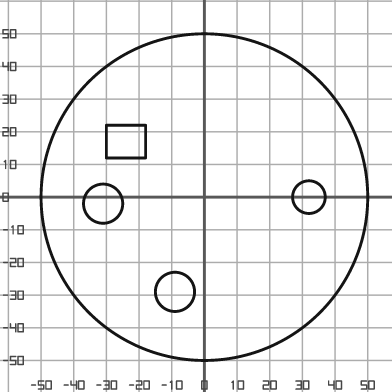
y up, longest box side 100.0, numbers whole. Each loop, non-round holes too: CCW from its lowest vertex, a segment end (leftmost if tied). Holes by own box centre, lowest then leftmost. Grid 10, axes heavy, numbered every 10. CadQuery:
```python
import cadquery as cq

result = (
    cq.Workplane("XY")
    .moveTo(0.0, 0.0)
    .circle(50.0)
    .moveTo(-9.0, -29.0)
    .circle(6.0)
    .moveTo(-31.0, -2.0)
    .circle(6.0)
    .moveTo(32.0, 0.0)
    .circle(5.0)
    .moveTo(-30.0, 12.0)
    .lineTo(-18.0, 12.0)
    .lineTo(-18.0, 22.0)
    .lineTo(-30.0, 22.0)
    .close()
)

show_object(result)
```